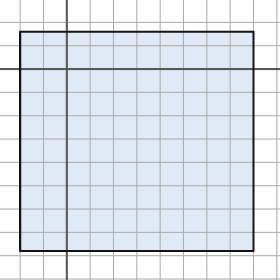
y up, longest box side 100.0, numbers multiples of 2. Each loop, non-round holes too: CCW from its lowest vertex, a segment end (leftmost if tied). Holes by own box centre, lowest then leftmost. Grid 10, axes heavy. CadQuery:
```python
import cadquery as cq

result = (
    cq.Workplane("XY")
    .moveTo(-20.0, -78.0)
    .lineTo(80.0, -78.0)
    .lineTo(80.0, 16.0)
    .lineTo(-20.0, 16.0)
    .close()
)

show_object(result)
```